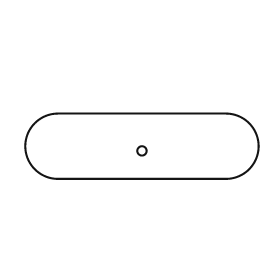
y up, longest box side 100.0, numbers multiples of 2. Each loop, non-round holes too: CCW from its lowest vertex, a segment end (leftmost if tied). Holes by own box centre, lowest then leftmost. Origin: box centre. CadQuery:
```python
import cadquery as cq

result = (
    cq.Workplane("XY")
    .moveTo(-36.0, -14.0)
    .lineTo(36.0, -14.0)
    .threePointArc((50.0, 0.0), (36.0, 14.0))
    .lineTo(-36.0, 14.0)
    .threePointArc((-50.0, 0.0), (-36.0, -14.0))
    .close()
    .moveTo(0.0, -2.0)
    .circle(2.0)
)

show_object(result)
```